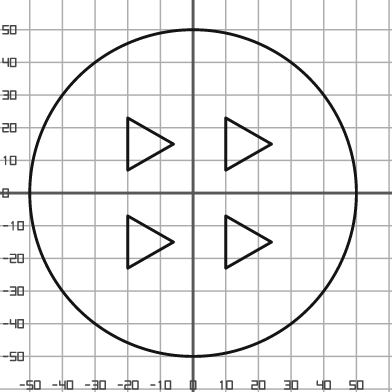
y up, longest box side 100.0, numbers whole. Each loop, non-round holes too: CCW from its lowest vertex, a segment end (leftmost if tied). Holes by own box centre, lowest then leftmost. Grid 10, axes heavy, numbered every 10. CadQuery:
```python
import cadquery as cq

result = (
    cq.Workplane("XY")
    .moveTo(0.0, 0.0)
    .circle(50.0)
    .moveTo(-20.0, -23.0)
    .lineTo(-6.0, -15.0)
    .lineTo(-20.0, -7.0)
    .close()
    .moveTo(10.0, -23.0)
    .lineTo(24.0, -15.0)
    .lineTo(10.0, -7.0)
    .close()
    .moveTo(-20.0, 7.0)
    .lineTo(-6.0, 15.0)
    .lineTo(-20.0, 23.0)
    .close()
    .moveTo(10.0, 7.0)
    .lineTo(24.0, 15.0)
    .lineTo(10.0, 23.0)
    .close()
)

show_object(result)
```